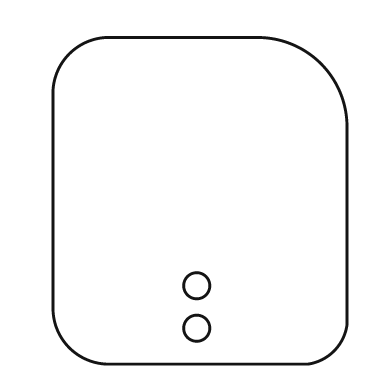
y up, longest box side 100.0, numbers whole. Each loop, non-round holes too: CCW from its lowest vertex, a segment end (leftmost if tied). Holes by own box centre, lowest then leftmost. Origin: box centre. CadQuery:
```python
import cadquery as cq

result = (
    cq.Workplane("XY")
    .moveTo(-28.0, -50.0)
    .lineTo(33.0, -50.0)
    .threePointArc((41.0, -46.0), (45.0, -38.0))
    .lineTo(45.0, 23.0)
    .threePointArc((37.0, 42.0), (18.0, 50.0))
    .lineTo(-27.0, 50.0)
    .threePointArc((-40.0, 45.0), (-45.0, 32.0))
    .lineTo(-45.0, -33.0)
    .threePointArc((-40.0, -45.0), (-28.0, -50.0))
    .close()
    .moveTo(-1.0, -39.0)
    .circle(4.0)
    .moveTo(-1.0, -26.0)
    .circle(4.0)
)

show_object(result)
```